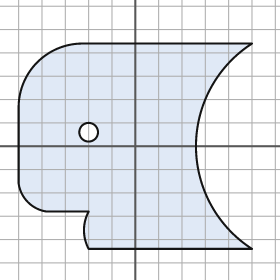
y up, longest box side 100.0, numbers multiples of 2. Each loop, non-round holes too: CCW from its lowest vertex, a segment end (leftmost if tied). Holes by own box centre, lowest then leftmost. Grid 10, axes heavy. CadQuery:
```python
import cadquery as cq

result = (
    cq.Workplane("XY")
    .moveTo(-20.0, -44.0)
    .lineTo(50.0, -44.0)
    .threePointArc((26.0, 0.0), (50.0, 44.0))
    .lineTo(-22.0, 44.0)
    .threePointArc((-42.0, 36.0), (-50.0, 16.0))
    .lineTo(-50.0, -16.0)
    .threePointArc((-46.0, -24.0), (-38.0, -28.0))
    .lineTo(-20.0, -28.0)
    .threePointArc((-22.0, -36.0), (-20.0, -44.0))
    .close()
    .moveTo(-20.0, 6.0)
    .circle(4.0)
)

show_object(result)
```